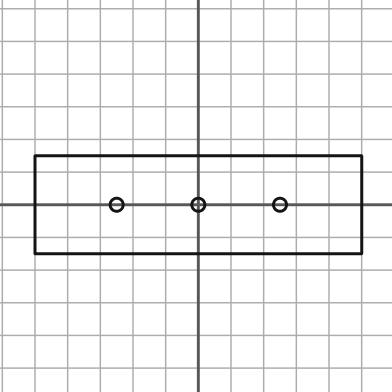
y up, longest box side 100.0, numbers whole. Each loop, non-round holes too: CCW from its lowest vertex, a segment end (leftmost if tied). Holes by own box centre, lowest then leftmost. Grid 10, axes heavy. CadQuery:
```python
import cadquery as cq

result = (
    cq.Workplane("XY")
    .moveTo(-50.0, -15.0)
    .lineTo(50.0, -15.0)
    .lineTo(50.0, 15.0)
    .lineTo(-50.0, 15.0)
    .close()
    .moveTo(-25.0, 0.0)
    .circle(2.0)
    .moveTo(0.0, 0.0)
    .circle(2.0)
    .moveTo(25.0, 0.0)
    .circle(2.0)
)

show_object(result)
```